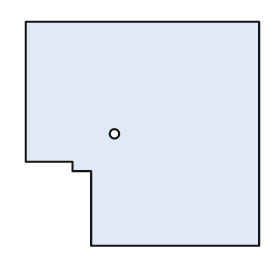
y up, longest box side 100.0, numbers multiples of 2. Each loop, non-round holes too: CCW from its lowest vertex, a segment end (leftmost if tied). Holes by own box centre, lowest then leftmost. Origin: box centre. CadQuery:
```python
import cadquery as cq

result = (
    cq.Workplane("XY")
    .moveTo(-22.0, -48.0)
    .lineTo(50.0, -48.0)
    .lineTo(50.0, 48.0)
    .lineTo(-50.0, 48.0)
    .lineTo(-50.0, -12.0)
    .lineTo(-30.0, -12.0)
    .lineTo(-30.0, -16.0)
    .lineTo(-22.0, -16.0)
    .close()
    .moveTo(-12.0, 0.0)
    .circle(2.0)
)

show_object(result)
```